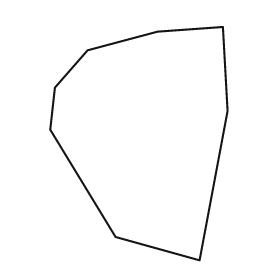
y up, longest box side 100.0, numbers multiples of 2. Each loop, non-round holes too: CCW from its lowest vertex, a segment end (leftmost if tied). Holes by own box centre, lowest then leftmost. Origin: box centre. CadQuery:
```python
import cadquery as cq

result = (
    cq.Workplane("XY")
    .moveTo(26.0, -50.0)
    .lineTo(38.0, 14.0)
    .lineTo(36.0, 50.0)
    .lineTo(8.0, 48.0)
    .lineTo(-22.0, 40.0)
    .lineTo(-36.0, 24.0)
    .lineTo(-38.0, 6.0)
    .lineTo(-10.0, -40.0)
    .close()
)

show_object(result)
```